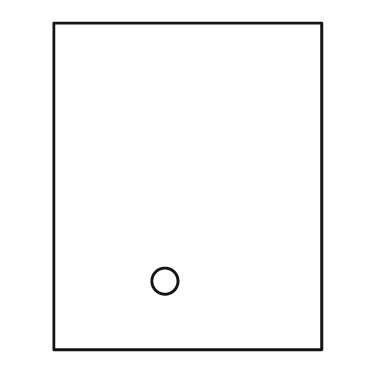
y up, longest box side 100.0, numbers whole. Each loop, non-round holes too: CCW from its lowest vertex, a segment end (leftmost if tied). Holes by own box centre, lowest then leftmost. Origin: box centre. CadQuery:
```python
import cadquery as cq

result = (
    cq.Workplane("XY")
    .moveTo(-41.0, -50.0)
    .lineTo(41.0, -50.0)
    .lineTo(41.0, 50.0)
    .lineTo(-41.0, 50.0)
    .close()
    .moveTo(-7.0, -29.0)
    .circle(4.0)
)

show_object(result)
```